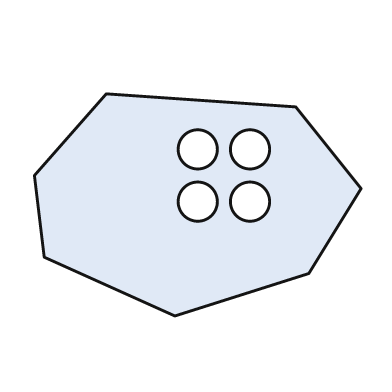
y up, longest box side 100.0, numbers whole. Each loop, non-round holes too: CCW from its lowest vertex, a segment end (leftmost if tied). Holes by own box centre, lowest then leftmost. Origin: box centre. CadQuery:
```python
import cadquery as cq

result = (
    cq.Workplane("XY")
    .moveTo(-7.0, -34.0)
    .lineTo(34.0, -21.0)
    .lineTo(50.0, 5.0)
    .lineTo(30.0, 30.0)
    .lineTo(-28.0, 34.0)
    .lineTo(-50.0, 9.0)
    .lineTo(-47.0, -16.0)
    .close()
    .moveTo(0.0, 1.0)
    .circle(6.0)
    .moveTo(16.0, 1.0)
    .circle(6.0)
    .moveTo(0.0, 17.0)
    .circle(6.0)
    .moveTo(16.0, 17.0)
    .circle(6.0)
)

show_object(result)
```